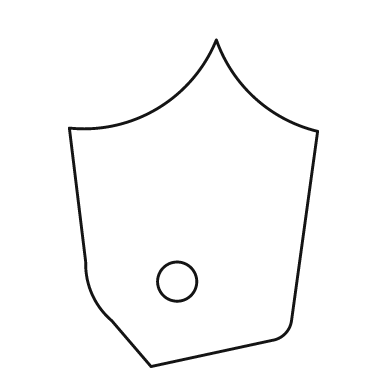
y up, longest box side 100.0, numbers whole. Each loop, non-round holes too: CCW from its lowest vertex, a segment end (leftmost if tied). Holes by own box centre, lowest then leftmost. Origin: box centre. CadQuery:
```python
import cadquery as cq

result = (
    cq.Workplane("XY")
    .moveTo(-13.0, -50.0)
    .lineTo(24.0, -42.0)
    .threePointArc((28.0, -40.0), (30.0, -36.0))
    .lineTo(38.0, 22.0)
    .threePointArc((19.0, 32.0), (7.0, 50.0))
    .threePointArc((-11.0, 29.0), (-38.0, 23.0))
    .lineTo(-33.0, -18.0)
    .threePointArc((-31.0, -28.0), (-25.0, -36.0))
    .close()
    .moveTo(-5.0, -24.0)
    .circle(6.0)
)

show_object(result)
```